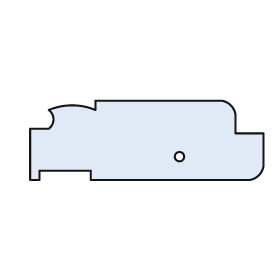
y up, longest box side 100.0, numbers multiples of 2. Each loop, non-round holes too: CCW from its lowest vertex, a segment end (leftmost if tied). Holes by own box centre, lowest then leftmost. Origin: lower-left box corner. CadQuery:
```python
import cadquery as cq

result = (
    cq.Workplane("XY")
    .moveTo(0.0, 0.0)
    .lineTo(4.0, 0.0)
    .lineTo(4.0, 4.0)
    .lineTo(26.0, 4.0)
    .lineTo(26.0, 0.0)
    .lineTo(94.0, 0.0)
    .threePointArc((98.0, 2.0), (100.0, 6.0))
    .lineTo(100.0, 20.0)
    .lineTo(88.0, 20.0)
    .lineTo(88.0, 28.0)
    .threePointArc((86.0, 32.0), (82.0, 34.0))
    .lineTo(28.0, 34.0)
    .lineTo(28.0, 30.0)
    .threePointArc((18.0, 32.0), (8.0, 30.0))
    .threePointArc((10.0, 26.0), (8.0, 22.0))
    .lineTo(0.0, 22.0)
    .close()
    .moveTo(64.0, 10.0)
    .circle(2.0)
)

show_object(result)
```